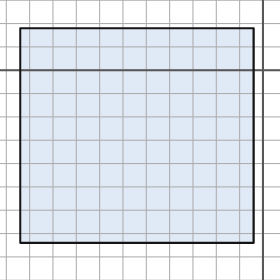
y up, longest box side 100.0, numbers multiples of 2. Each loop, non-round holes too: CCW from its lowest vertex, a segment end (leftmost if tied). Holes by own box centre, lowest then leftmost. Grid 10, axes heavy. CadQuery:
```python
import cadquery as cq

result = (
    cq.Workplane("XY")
    .moveTo(-104.0, -74.0)
    .lineTo(-4.0, -74.0)
    .lineTo(-4.0, 18.0)
    .lineTo(-104.0, 18.0)
    .close()
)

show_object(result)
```